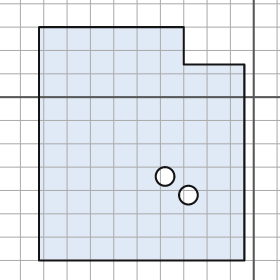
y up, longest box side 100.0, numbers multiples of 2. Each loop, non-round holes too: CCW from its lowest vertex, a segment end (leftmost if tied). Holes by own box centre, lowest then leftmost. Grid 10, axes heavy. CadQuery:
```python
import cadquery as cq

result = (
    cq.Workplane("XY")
    .moveTo(-92.0, -70.0)
    .lineTo(-4.0, -70.0)
    .lineTo(-4.0, 14.0)
    .lineTo(-30.0, 14.0)
    .lineTo(-30.0, 30.0)
    .lineTo(-92.0, 30.0)
    .close()
    .moveTo(-28.0, -42.0)
    .circle(4.0)
    .moveTo(-38.0, -34.0)
    .circle(4.0)
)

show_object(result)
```